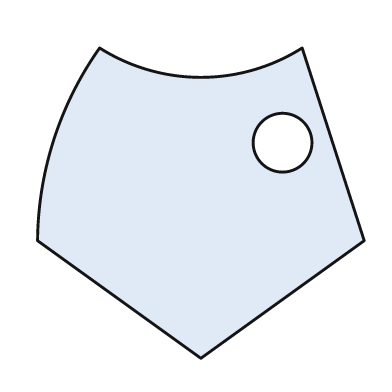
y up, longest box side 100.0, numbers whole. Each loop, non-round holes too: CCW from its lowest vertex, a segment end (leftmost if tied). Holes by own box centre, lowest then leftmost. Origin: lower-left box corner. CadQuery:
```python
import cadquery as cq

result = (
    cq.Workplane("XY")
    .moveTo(50.0, 0.0)
    .lineTo(100.0, 36.0)
    .lineTo(81.0, 95.0)
    .threePointArc((50.0, 86.0), (19.0, 95.0))
    .threePointArc((5.0, 67.0), (0.0, 36.0))
    .close()
    .moveTo(75.0, 66.0)
    .circle(9.0)
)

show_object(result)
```